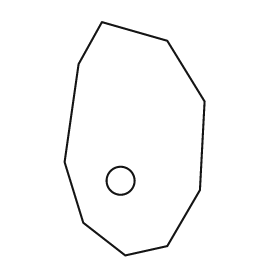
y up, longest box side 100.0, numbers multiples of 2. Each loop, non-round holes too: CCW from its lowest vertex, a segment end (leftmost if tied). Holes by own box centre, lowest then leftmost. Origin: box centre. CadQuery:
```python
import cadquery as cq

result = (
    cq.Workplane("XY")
    .moveTo(-4.0, -50.0)
    .lineTo(14.0, -46.0)
    .lineTo(28.0, -22.0)
    .lineTo(30.0, 16.0)
    .lineTo(14.0, 42.0)
    .lineTo(-14.0, 50.0)
    .lineTo(-24.0, 32.0)
    .lineTo(-30.0, -10.0)
    .lineTo(-22.0, -36.0)
    .close()
    .moveTo(-6.0, -18.0)
    .circle(6.0)
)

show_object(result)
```